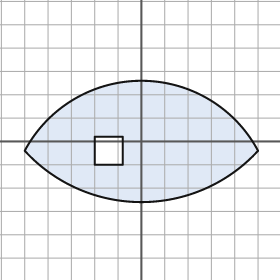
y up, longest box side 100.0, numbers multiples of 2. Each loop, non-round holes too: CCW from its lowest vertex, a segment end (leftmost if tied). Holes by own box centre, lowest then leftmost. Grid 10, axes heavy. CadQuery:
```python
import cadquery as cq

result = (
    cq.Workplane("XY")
    .moveTo(-50.0, -4.0)
    .threePointArc((0.0, -26.0), (50.0, -4.0))
    .threePointArc((0.0, 26.0), (-50.0, -4.0))
    .close()
    .moveTo(-20.0, -10.0)
    .lineTo(-8.0, -10.0)
    .lineTo(-8.0, 2.0)
    .lineTo(-20.0, 2.0)
    .close()
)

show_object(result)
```